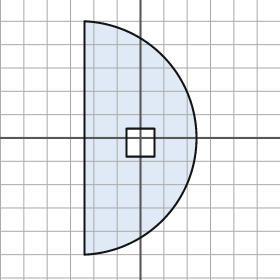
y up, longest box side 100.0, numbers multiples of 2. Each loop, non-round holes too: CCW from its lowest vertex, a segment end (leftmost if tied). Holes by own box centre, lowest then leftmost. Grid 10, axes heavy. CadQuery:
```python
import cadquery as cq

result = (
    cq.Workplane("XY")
    .moveTo(-24.0, -50.0)
    .threePointArc((24.0, 0.0), (-24.0, 50.0))
    .close()
    .moveTo(-6.0, -8.0)
    .lineTo(6.0, -8.0)
    .lineTo(6.0, 4.0)
    .lineTo(-6.0, 4.0)
    .close()
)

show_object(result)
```